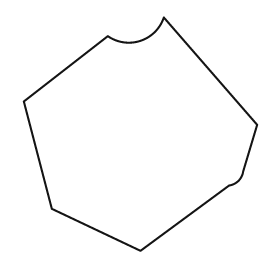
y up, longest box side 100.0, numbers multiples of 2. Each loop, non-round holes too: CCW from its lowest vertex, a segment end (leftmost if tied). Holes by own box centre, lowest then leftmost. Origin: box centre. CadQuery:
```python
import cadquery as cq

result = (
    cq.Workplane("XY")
    .moveTo(0.0, -50.0)
    .lineTo(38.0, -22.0)
    .threePointArc((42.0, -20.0), (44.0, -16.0))
    .lineTo(50.0, 4.0)
    .lineTo(10.0, 50.0)
    .threePointArc((0.0, 40.0), (-14.0, 42.0))
    .lineTo(-50.0, 14.0)
    .lineTo(-38.0, -32.0)
    .close()
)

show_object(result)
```